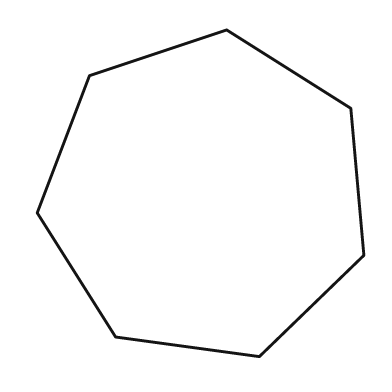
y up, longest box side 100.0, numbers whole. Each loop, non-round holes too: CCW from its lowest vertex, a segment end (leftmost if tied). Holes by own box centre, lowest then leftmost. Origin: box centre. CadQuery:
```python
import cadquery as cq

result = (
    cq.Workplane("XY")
    .moveTo(18.0, -50.0)
    .lineTo(50.0, -19.0)
    .lineTo(46.0, 26.0)
    .lineTo(8.0, 50.0)
    .lineTo(-34.0, 36.0)
    .lineTo(-50.0, -6.0)
    .lineTo(-26.0, -44.0)
    .close()
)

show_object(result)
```